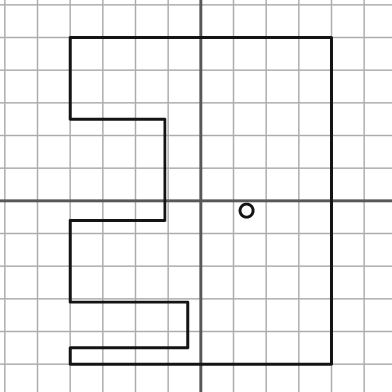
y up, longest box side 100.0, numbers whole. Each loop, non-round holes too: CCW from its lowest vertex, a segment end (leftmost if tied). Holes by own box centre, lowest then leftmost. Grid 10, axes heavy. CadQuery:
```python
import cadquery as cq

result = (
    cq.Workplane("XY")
    .moveTo(-40.0, -50.0)
    .lineTo(40.0, -50.0)
    .lineTo(40.0, 50.0)
    .lineTo(-40.0, 50.0)
    .lineTo(-40.0, 25.0)
    .lineTo(-11.0, 25.0)
    .lineTo(-11.0, -6.0)
    .lineTo(-40.0, -6.0)
    .lineTo(-40.0, -31.0)
    .lineTo(-4.0, -31.0)
    .lineTo(-4.0, -45.0)
    .lineTo(-40.0, -45.0)
    .close()
    .moveTo(14.0, -3.0)
    .circle(2.0)
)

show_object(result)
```